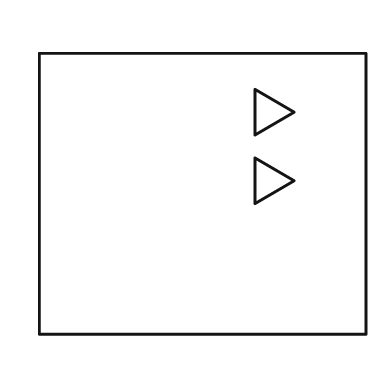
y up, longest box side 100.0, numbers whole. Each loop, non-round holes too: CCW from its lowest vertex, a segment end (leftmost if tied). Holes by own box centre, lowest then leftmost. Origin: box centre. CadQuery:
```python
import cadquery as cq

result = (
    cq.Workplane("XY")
    .moveTo(-50.0, -43.0)
    .lineTo(50.0, -43.0)
    .lineTo(50.0, 43.0)
    .lineTo(-50.0, 43.0)
    .close()
    .moveTo(16.0, -3.0)
    .lineTo(28.0, 4.0)
    .lineTo(16.0, 11.0)
    .close()
    .moveTo(16.0, 18.0)
    .lineTo(28.0, 25.0)
    .lineTo(16.0, 32.0)
    .close()
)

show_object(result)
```